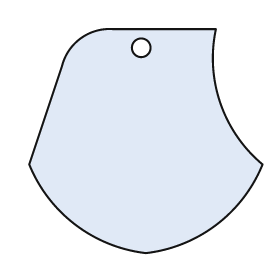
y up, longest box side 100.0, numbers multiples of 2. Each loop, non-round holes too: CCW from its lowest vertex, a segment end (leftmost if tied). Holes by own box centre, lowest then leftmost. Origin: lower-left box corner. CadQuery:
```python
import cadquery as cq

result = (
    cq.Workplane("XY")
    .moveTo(50.0, 0.0)
    .threePointArc((80.0, 12.0), (100.0, 38.0))
    .threePointArc((82.0, 64.0), (80.0, 96.0))
    .lineTo(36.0, 96.0)
    .threePointArc((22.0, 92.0), (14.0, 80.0))
    .lineTo(0.0, 38.0)
    .threePointArc((20.0, 12.0), (50.0, 0.0))
    .close()
    .moveTo(48.0, 88.0)
    .circle(4.0)
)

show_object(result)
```